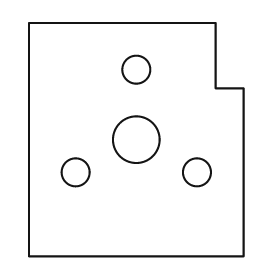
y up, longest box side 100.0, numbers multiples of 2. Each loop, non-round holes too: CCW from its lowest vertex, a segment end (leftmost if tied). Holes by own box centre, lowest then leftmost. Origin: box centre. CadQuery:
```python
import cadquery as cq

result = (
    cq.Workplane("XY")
    .moveTo(-46.0, -50.0)
    .lineTo(46.0, -50.0)
    .lineTo(46.0, 22.0)
    .lineTo(34.0, 22.0)
    .lineTo(34.0, 50.0)
    .lineTo(-46.0, 50.0)
    .close()
    .moveTo(-26.0, -14.0)
    .circle(6.0)
    .moveTo(26.0, -14.0)
    .circle(6.0)
    .moveTo(0.0, 0.0)
    .circle(10.0)
    .moveTo(0.0, 30.0)
    .circle(6.0)
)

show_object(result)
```